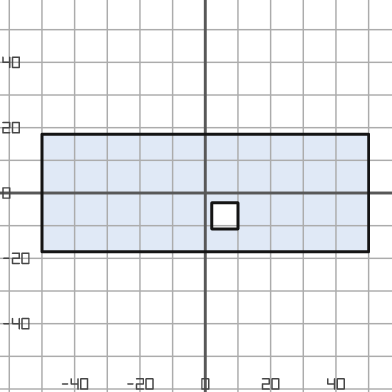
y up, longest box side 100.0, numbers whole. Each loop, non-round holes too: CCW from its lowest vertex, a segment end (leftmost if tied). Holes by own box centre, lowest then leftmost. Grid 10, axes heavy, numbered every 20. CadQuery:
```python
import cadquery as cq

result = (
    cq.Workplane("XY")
    .moveTo(-50.0, -18.0)
    .lineTo(50.0, -18.0)
    .lineTo(50.0, 18.0)
    .lineTo(-50.0, 18.0)
    .close()
    .moveTo(2.0, -11.0)
    .lineTo(10.0, -11.0)
    .lineTo(10.0, -3.0)
    .lineTo(2.0, -3.0)
    .close()
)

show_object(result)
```